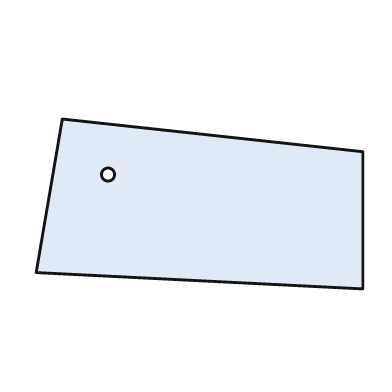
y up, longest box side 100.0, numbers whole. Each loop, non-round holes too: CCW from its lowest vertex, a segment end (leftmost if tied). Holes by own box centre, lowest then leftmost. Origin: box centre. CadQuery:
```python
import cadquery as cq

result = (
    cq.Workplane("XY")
    .moveTo(50.0, -26.0)
    .lineTo(50.0, 16.0)
    .lineTo(-42.0, 26.0)
    .lineTo(-50.0, -21.0)
    .close()
    .moveTo(-28.0, 9.0)
    .circle(2.0)
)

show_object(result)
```